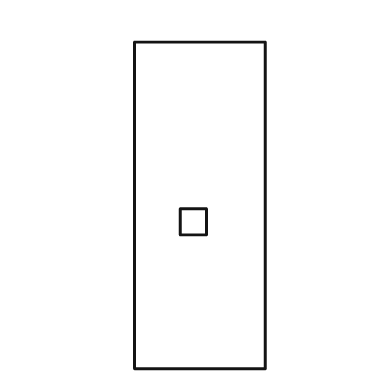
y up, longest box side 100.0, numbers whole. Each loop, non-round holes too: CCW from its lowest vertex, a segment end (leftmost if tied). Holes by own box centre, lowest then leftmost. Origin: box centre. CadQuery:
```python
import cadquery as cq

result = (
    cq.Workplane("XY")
    .moveTo(-20.0, -50.0)
    .lineTo(20.0, -50.0)
    .lineTo(20.0, 50.0)
    .lineTo(-20.0, 50.0)
    .close()
    .moveTo(-6.0, -9.0)
    .lineTo(2.0, -9.0)
    .lineTo(2.0, -1.0)
    .lineTo(-6.0, -1.0)
    .close()
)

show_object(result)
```